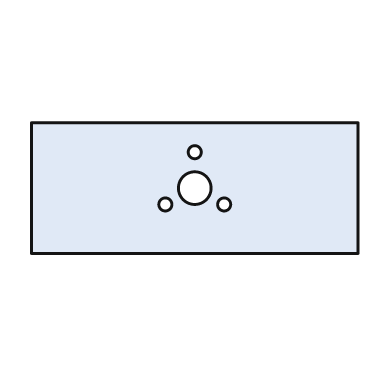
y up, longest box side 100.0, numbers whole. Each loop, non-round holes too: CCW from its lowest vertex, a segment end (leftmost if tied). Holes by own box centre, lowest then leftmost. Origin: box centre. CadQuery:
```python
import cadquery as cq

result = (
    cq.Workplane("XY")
    .moveTo(-50.0, -20.0)
    .lineTo(50.0, -20.0)
    .lineTo(50.0, 20.0)
    .lineTo(-50.0, 20.0)
    .close()
    .moveTo(-9.0, -5.0)
    .circle(2.0)
    .moveTo(9.0, -5.0)
    .circle(2.0)
    .moveTo(0.0, 0.0)
    .circle(5.0)
    .moveTo(0.0, 11.0)
    .circle(2.0)
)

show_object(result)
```